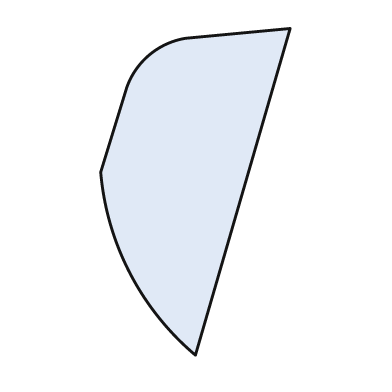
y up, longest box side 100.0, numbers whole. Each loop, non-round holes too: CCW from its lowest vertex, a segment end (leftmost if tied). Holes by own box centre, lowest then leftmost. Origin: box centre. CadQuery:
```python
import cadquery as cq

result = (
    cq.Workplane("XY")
    .moveTo(0.0, -50.0)
    .lineTo(29.0, 50.0)
    .lineTo(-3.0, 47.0)
    .threePointArc((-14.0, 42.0), (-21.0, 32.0))
    .lineTo(-29.0, 6.0)
    .threePointArc((-20.0, -25.0), (0.0, -50.0))
    .close()
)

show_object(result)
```